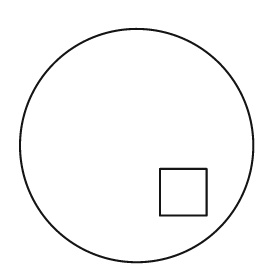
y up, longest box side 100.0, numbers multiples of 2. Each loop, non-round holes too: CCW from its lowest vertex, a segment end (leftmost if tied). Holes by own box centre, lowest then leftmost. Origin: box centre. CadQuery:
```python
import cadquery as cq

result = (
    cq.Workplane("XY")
    .moveTo(0.0, 0.0)
    .circle(50.0)
    .moveTo(10.0, -30.0)
    .lineTo(30.0, -30.0)
    .lineTo(30.0, -10.0)
    .lineTo(10.0, -10.0)
    .close()
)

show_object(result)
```